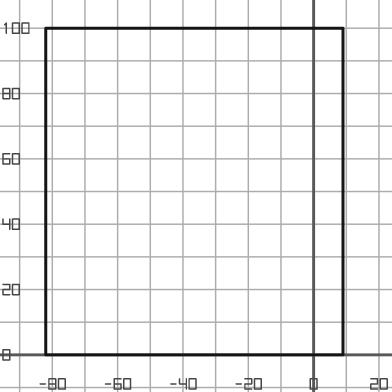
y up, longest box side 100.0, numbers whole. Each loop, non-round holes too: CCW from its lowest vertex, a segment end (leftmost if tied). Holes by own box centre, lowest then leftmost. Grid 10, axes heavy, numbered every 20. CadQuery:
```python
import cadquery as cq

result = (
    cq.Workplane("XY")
    .moveTo(-82.0, 0.0)
    .lineTo(9.0, 0.0)
    .lineTo(9.0, 100.0)
    .lineTo(-82.0, 100.0)
    .close()
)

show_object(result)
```